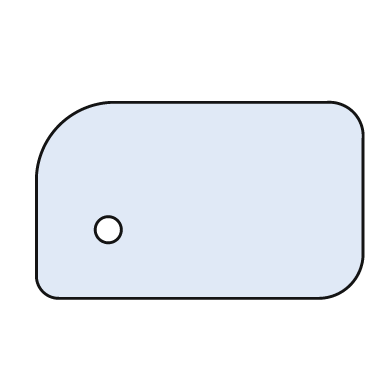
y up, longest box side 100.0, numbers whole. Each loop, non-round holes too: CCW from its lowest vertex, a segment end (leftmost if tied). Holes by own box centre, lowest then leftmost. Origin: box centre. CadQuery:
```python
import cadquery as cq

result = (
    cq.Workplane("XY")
    .moveTo(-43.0, -30.0)
    .lineTo(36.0, -30.0)
    .threePointArc((46.0, -26.0), (50.0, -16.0))
    .lineTo(50.0, 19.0)
    .threePointArc((47.0, 27.0), (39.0, 30.0))
    .lineTo(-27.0, 30.0)
    .threePointArc((-43.0, 23.0), (-50.0, 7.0))
    .lineTo(-50.0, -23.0)
    .threePointArc((-48.0, -28.0), (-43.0, -30.0))
    .close()
    .moveTo(-28.0, -9.0)
    .circle(4.0)
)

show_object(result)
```